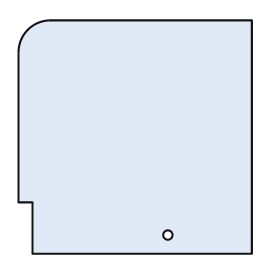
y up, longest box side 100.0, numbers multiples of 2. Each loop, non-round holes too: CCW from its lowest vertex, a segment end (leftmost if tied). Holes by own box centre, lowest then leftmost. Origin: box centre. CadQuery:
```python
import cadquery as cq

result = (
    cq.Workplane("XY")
    .moveTo(-44.0, -50.0)
    .lineTo(50.0, -50.0)
    .lineTo(50.0, 50.0)
    .lineTo(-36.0, 50.0)
    .threePointArc((-46.0, 46.0), (-50.0, 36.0))
    .lineTo(-50.0, -28.0)
    .lineTo(-44.0, -28.0)
    .close()
    .moveTo(14.0, -42.0)
    .circle(2.0)
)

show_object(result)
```